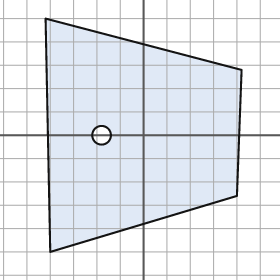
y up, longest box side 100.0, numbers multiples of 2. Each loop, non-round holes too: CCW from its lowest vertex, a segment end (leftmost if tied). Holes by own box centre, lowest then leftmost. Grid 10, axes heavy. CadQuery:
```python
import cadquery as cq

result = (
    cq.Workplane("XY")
    .moveTo(-40.0, -50.0)
    .lineTo(40.0, -26.0)
    .lineTo(42.0, 28.0)
    .lineTo(-42.0, 50.0)
    .close()
    .moveTo(-18.0, 0.0)
    .circle(4.0)
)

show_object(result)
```